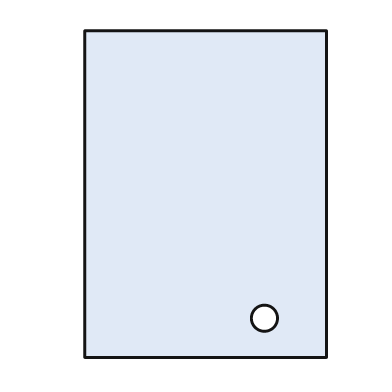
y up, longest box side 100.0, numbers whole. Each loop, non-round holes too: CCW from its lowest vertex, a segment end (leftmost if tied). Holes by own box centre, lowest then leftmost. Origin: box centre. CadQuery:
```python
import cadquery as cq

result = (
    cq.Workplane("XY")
    .moveTo(-37.0, -50.0)
    .lineTo(37.0, -50.0)
    .lineTo(37.0, 50.0)
    .lineTo(-37.0, 50.0)
    .close()
    .moveTo(18.0, -38.0)
    .circle(4.0)
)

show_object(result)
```